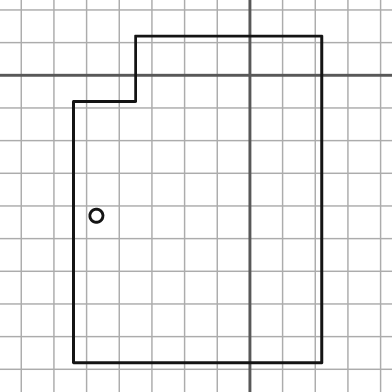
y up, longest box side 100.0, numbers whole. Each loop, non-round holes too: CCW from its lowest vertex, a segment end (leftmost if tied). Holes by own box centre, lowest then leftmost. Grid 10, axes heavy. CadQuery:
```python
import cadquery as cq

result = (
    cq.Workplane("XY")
    .moveTo(-54.0, -88.0)
    .lineTo(22.0, -88.0)
    .lineTo(22.0, 12.0)
    .lineTo(-35.0, 12.0)
    .lineTo(-35.0, -8.0)
    .lineTo(-54.0, -8.0)
    .close()
    .moveTo(-47.0, -43.0)
    .circle(2.0)
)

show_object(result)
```